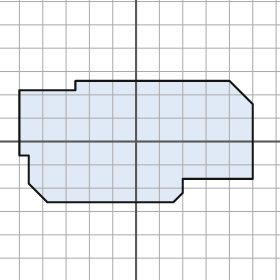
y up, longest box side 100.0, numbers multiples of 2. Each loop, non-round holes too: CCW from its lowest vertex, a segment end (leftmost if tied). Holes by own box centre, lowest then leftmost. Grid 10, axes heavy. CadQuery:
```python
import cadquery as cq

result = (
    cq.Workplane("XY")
    .moveTo(-38.0, -26.0)
    .lineTo(16.0, -26.0)
    .lineTo(20.0, -22.0)
    .lineTo(20.0, -16.0)
    .lineTo(50.0, -16.0)
    .lineTo(50.0, 16.0)
    .lineTo(40.0, 26.0)
    .lineTo(-26.0, 26.0)
    .lineTo(-26.0, 22.0)
    .lineTo(-50.0, 22.0)
    .lineTo(-50.0, -6.0)
    .lineTo(-46.0, -6.0)
    .lineTo(-46.0, -18.0)
    .close()
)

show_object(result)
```